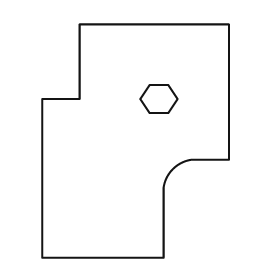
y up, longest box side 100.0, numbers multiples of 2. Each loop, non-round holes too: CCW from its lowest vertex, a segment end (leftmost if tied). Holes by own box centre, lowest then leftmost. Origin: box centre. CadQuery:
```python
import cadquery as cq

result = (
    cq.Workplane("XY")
    .moveTo(-40.0, -50.0)
    .lineTo(12.0, -50.0)
    .lineTo(12.0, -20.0)
    .threePointArc((16.0, -12.0), (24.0, -8.0))
    .lineTo(40.0, -8.0)
    .lineTo(40.0, 50.0)
    .lineTo(-24.0, 50.0)
    .lineTo(-24.0, 18.0)
    .lineTo(-40.0, 18.0)
    .close()
    .moveTo(6.0, 12.0)
    .lineTo(14.0, 12.0)
    .lineTo(18.0, 18.0)
    .lineTo(14.0, 24.0)
    .lineTo(6.0, 24.0)
    .lineTo(2.0, 18.0)
    .close()
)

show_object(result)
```